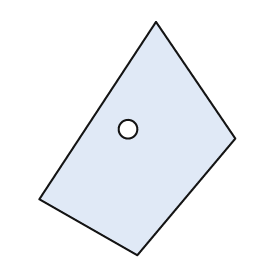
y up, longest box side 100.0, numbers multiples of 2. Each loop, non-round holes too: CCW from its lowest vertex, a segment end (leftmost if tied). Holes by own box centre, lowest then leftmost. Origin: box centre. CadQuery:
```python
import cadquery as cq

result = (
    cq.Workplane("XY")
    .moveTo(0.0, -50.0)
    .lineTo(42.0, 0.0)
    .lineTo(8.0, 50.0)
    .lineTo(-42.0, -26.0)
    .close()
    .moveTo(-4.0, 4.0)
    .circle(4.0)
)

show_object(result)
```